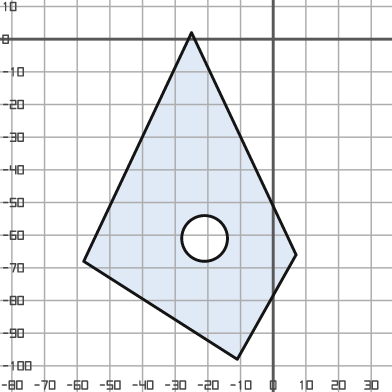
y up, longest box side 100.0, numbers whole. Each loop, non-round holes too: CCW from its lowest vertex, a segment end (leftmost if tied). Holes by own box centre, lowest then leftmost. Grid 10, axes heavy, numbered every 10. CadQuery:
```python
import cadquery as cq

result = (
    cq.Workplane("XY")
    .moveTo(-11.0, -98.0)
    .lineTo(7.0, -66.0)
    .lineTo(-25.0, 2.0)
    .lineTo(-58.0, -68.0)
    .close()
    .moveTo(-21.0, -61.0)
    .circle(7.0)
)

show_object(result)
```